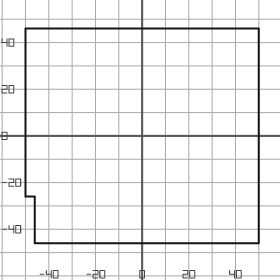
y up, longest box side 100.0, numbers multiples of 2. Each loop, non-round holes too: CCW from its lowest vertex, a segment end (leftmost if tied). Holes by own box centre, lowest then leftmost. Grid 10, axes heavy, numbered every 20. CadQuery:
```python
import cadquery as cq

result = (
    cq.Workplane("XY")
    .moveTo(-46.0, -46.0)
    .lineTo(50.0, -46.0)
    .lineTo(50.0, 46.0)
    .lineTo(-50.0, 46.0)
    .lineTo(-50.0, -26.0)
    .lineTo(-46.0, -26.0)
    .close()
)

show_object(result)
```